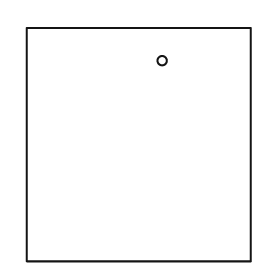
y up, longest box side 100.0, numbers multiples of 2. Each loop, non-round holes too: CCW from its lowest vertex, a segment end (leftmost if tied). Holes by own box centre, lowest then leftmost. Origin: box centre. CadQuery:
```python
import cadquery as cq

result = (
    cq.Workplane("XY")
    .moveTo(-48.0, -50.0)
    .lineTo(48.0, -50.0)
    .lineTo(48.0, 50.0)
    .lineTo(-48.0, 50.0)
    .close()
    .moveTo(10.0, 36.0)
    .circle(2.0)
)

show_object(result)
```